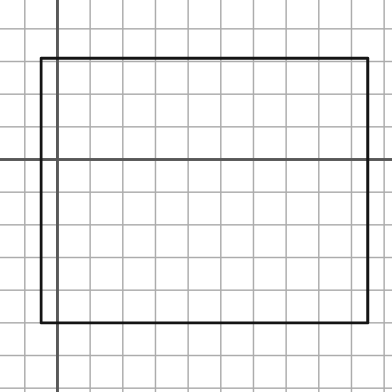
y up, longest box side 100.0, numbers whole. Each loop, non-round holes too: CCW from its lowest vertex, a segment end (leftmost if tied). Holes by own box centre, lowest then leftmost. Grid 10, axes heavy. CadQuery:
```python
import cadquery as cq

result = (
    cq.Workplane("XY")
    .moveTo(-5.0, -50.0)
    .lineTo(95.0, -50.0)
    .lineTo(95.0, 31.0)
    .lineTo(-5.0, 31.0)
    .close()
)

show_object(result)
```